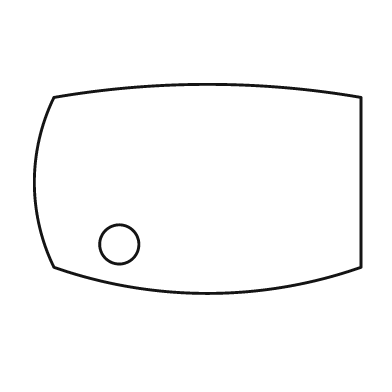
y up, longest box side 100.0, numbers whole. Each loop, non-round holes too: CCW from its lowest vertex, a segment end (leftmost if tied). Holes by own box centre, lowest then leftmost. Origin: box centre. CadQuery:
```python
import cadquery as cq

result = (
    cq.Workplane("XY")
    .moveTo(-44.0, -24.0)
    .threePointArc((3.0, -32.0), (50.0, -24.0))
    .lineTo(50.0, 28.0)
    .threePointArc((3.0, 32.0), (-44.0, 28.0))
    .threePointArc((-50.0, 2.0), (-44.0, -24.0))
    .close()
    .moveTo(-24.0, -17.0)
    .circle(6.0)
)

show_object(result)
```